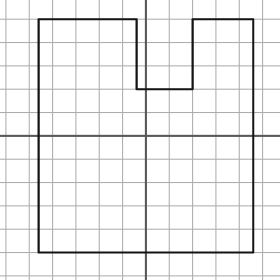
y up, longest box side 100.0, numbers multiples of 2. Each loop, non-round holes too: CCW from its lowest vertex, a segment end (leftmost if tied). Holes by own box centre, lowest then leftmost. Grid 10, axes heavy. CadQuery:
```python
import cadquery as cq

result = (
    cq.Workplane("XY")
    .moveTo(-46.0, -50.0)
    .lineTo(46.0, -50.0)
    .lineTo(46.0, 50.0)
    .lineTo(20.0, 50.0)
    .lineTo(20.0, 20.0)
    .lineTo(-4.0, 20.0)
    .lineTo(-4.0, 50.0)
    .lineTo(-46.0, 50.0)
    .close()
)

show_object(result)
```